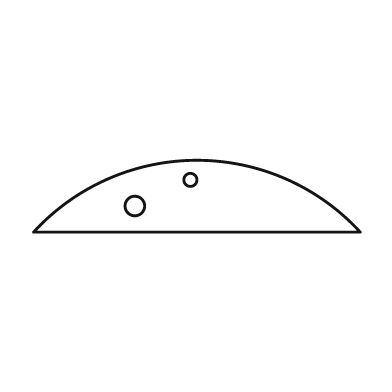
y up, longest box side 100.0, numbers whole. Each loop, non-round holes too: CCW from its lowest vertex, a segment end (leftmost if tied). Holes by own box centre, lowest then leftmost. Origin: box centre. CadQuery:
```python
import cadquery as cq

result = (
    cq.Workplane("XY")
    .moveTo(-50.0, -11.0)
    .lineTo(50.0, -11.0)
    .threePointArc((0.0, 11.0), (-50.0, -11.0))
    .close()
    .moveTo(-19.0, -3.0)
    .circle(3.0)
    .moveTo(-2.0, 5.0)
    .circle(2.0)
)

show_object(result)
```